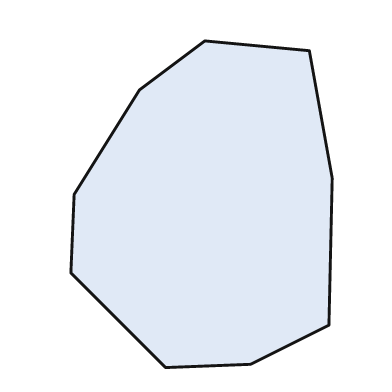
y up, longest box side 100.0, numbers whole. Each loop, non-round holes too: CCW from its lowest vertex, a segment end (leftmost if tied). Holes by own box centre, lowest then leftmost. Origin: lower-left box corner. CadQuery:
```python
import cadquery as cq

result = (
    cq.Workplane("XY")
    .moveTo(29.0, 0.0)
    .lineTo(55.0, 1.0)
    .lineTo(79.0, 13.0)
    .lineTo(80.0, 58.0)
    .lineTo(73.0, 97.0)
    .lineTo(41.0, 100.0)
    .lineTo(21.0, 85.0)
    .lineTo(1.0, 53.0)
    .lineTo(0.0, 29.0)
    .close()
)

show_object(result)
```